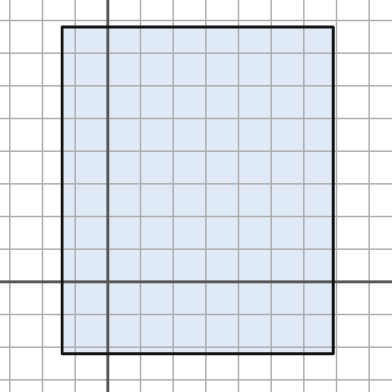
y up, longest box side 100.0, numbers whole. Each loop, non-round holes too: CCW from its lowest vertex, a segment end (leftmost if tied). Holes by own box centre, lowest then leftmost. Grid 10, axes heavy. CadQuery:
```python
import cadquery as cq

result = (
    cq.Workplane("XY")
    .moveTo(-14.0, -22.0)
    .lineTo(69.0, -22.0)
    .lineTo(69.0, 78.0)
    .lineTo(-14.0, 78.0)
    .close()
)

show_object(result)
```